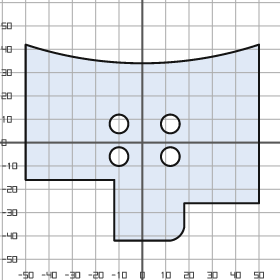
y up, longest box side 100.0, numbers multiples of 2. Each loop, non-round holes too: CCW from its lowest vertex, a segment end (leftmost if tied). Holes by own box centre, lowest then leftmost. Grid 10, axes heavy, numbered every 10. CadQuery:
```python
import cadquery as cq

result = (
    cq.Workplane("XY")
    .moveTo(-12.0, -42.0)
    .lineTo(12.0, -42.0)
    .threePointArc((16.0, -40.0), (18.0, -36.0))
    .lineTo(18.0, -26.0)
    .lineTo(50.0, -26.0)
    .lineTo(50.0, 42.0)
    .threePointArc((0.0, 34.0), (-50.0, 42.0))
    .lineTo(-50.0, -16.0)
    .lineTo(-12.0, -16.0)
    .close()
    .moveTo(-10.0, -6.0)
    .circle(4.0)
    .moveTo(12.0, -6.0)
    .circle(4.0)
    .moveTo(-10.0, 8.0)
    .circle(4.0)
    .moveTo(12.0, 8.0)
    .circle(4.0)
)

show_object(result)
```